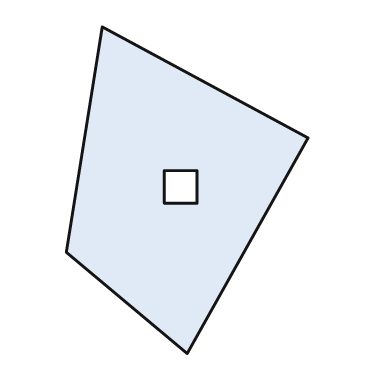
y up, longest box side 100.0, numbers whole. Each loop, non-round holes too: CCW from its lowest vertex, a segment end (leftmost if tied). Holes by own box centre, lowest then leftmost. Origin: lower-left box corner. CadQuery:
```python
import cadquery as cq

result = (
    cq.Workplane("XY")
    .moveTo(37.0, 0.0)
    .lineTo(74.0, 66.0)
    .lineTo(11.0, 100.0)
    .lineTo(0.0, 31.0)
    .close()
    .moveTo(30.0, 46.0)
    .lineTo(40.0, 46.0)
    .lineTo(40.0, 56.0)
    .lineTo(30.0, 56.0)
    .close()
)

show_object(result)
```